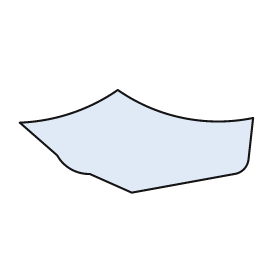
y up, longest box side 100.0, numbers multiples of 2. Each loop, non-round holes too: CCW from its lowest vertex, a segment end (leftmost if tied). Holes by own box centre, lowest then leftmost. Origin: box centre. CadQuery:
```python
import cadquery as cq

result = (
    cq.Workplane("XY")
    .moveTo(-2.0, -22.0)
    .lineTo(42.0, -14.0)
    .threePointArc((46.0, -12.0), (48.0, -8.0))
    .lineTo(50.0, 10.0)
    .threePointArc((20.0, 10.0), (-8.0, 22.0))
    .threePointArc((-28.0, 12.0), (-50.0, 8.0))
    .lineTo(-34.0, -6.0)
    .threePointArc((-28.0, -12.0), (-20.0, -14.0))
    .close()
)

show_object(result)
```